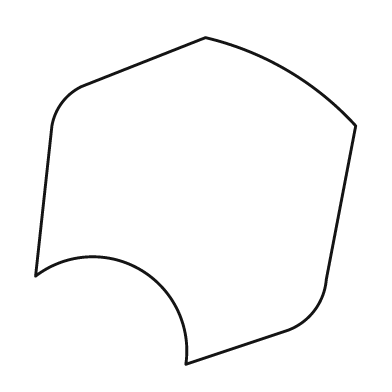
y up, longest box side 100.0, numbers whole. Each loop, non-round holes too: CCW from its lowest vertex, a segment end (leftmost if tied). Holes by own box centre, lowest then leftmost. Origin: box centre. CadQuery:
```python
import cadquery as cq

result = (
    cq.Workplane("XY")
    .moveTo(-3.0, -50.0)
    .lineTo(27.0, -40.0)
    .threePointArc((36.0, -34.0), (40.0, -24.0))
    .lineTo(49.0, 23.0)
    .threePointArc((28.0, 40.0), (3.0, 50.0))
    .lineTo(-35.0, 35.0)
    .threePointArc((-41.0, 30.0), (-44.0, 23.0))
    .lineTo(-49.0, -23.0)
    .threePointArc((-17.0, -21.0), (-3.0, -50.0))
    .close()
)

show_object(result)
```